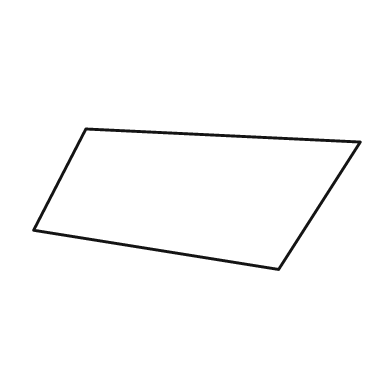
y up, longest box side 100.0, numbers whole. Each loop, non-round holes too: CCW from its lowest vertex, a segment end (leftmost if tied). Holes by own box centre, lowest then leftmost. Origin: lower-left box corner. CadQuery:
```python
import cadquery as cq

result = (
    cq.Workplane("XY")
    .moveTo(75.0, 0.0)
    .lineTo(100.0, 39.0)
    .lineTo(16.0, 43.0)
    .lineTo(0.0, 12.0)
    .close()
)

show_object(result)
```